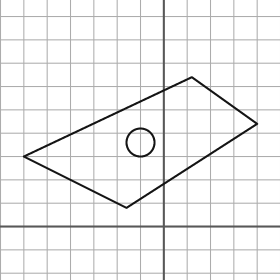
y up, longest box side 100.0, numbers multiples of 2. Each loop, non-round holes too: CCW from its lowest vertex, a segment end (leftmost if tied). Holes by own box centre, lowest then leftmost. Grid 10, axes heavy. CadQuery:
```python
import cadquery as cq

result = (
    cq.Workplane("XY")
    .moveTo(-16.0, 8.0)
    .lineTo(40.0, 44.0)
    .lineTo(12.0, 64.0)
    .lineTo(-60.0, 30.0)
    .close()
    .moveTo(-10.0, 36.0)
    .circle(6.0)
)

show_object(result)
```